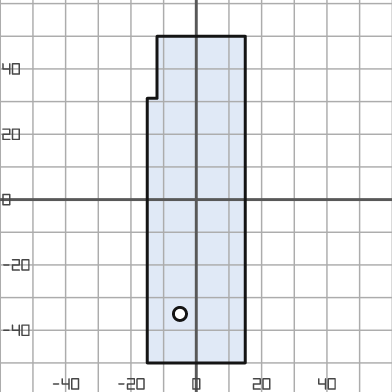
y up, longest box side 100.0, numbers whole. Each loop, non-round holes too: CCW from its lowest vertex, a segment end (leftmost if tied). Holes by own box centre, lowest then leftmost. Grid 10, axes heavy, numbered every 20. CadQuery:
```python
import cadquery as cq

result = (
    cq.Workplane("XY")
    .moveTo(-15.0, -50.0)
    .lineTo(15.0, -50.0)
    .lineTo(15.0, 50.0)
    .lineTo(-12.0, 50.0)
    .lineTo(-12.0, 31.0)
    .lineTo(-15.0, 31.0)
    .close()
    .moveTo(-5.0, -35.0)
    .circle(2.0)
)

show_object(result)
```